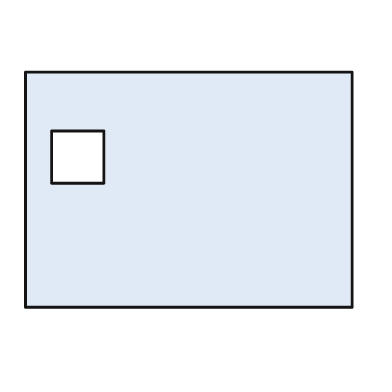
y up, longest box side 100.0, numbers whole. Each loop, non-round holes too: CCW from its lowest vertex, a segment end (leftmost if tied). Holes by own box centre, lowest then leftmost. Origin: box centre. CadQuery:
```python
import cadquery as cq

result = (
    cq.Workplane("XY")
    .moveTo(-50.0, -36.0)
    .lineTo(50.0, -36.0)
    .lineTo(50.0, 36.0)
    .lineTo(-50.0, 36.0)
    .close()
    .moveTo(-42.0, 2.0)
    .lineTo(-26.0, 2.0)
    .lineTo(-26.0, 18.0)
    .lineTo(-42.0, 18.0)
    .close()
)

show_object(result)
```